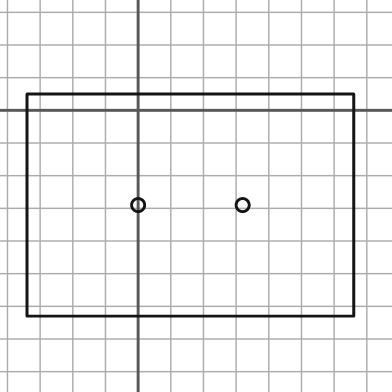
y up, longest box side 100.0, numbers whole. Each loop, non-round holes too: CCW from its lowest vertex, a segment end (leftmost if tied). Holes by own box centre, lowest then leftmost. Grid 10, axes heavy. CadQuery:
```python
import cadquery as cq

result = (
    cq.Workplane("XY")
    .moveTo(-34.0, -63.0)
    .lineTo(66.0, -63.0)
    .lineTo(66.0, 5.0)
    .lineTo(-34.0, 5.0)
    .close()
    .moveTo(0.0, -29.0)
    .circle(2.0)
    .moveTo(32.0, -29.0)
    .circle(2.0)
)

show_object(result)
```